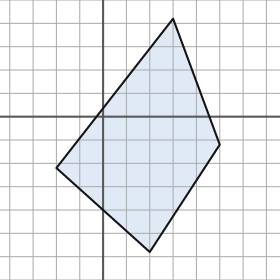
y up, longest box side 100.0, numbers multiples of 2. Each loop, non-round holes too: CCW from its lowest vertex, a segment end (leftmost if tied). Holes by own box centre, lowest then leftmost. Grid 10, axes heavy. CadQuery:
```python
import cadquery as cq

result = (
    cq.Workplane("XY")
    .moveTo(20.0, -58.0)
    .lineTo(50.0, -12.0)
    .lineTo(30.0, 42.0)
    .lineTo(-20.0, -22.0)
    .close()
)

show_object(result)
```